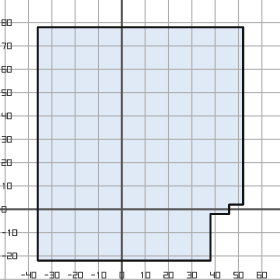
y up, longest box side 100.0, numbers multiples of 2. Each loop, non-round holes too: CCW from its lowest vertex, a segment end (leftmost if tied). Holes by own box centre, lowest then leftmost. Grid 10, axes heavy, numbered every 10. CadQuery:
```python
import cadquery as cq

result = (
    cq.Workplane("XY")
    .moveTo(-36.0, -22.0)
    .lineTo(38.0, -22.0)
    .lineTo(38.0, -2.0)
    .lineTo(46.0, -2.0)
    .lineTo(46.0, 2.0)
    .lineTo(52.0, 2.0)
    .lineTo(52.0, 78.0)
    .lineTo(-36.0, 78.0)
    .close()
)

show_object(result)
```